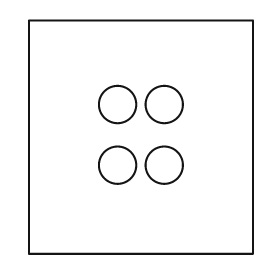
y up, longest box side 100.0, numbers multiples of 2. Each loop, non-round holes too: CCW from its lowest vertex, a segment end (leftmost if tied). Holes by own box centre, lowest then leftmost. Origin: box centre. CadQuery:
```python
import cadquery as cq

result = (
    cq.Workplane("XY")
    .moveTo(-48.0, -50.0)
    .lineTo(48.0, -50.0)
    .lineTo(48.0, 50.0)
    .lineTo(-48.0, 50.0)
    .close()
    .moveTo(-10.0, -12.0)
    .circle(8.0)
    .moveTo(10.0, -12.0)
    .circle(8.0)
    .moveTo(-10.0, 14.0)
    .circle(8.0)
    .moveTo(10.0, 14.0)
    .circle(8.0)
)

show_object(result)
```